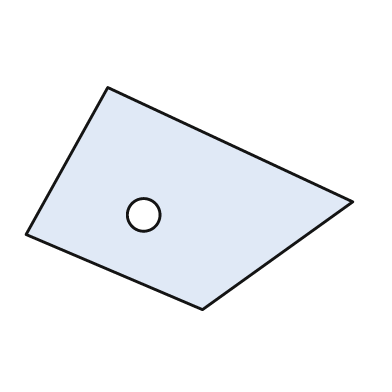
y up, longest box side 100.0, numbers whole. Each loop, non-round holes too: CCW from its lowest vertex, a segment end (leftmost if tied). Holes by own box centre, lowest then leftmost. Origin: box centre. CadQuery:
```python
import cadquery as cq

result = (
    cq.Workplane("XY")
    .moveTo(4.0, -34.0)
    .lineTo(50.0, -1.0)
    .lineTo(-25.0, 34.0)
    .lineTo(-50.0, -11.0)
    .close()
    .moveTo(-14.0, -5.0)
    .circle(5.0)
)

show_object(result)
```